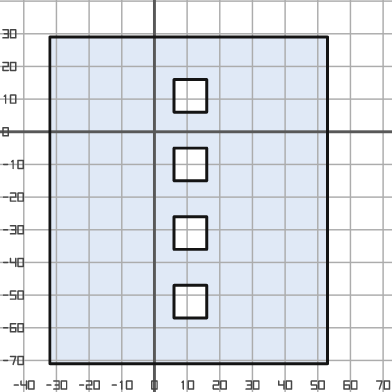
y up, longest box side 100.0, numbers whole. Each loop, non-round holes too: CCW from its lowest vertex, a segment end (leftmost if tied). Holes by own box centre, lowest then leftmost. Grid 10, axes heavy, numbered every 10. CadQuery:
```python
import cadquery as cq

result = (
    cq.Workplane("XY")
    .moveTo(-32.0, -71.0)
    .lineTo(53.0, -71.0)
    .lineTo(53.0, 29.0)
    .lineTo(-32.0, 29.0)
    .close()
    .moveTo(6.0, -57.0)
    .lineTo(16.0, -57.0)
    .lineTo(16.0, -47.0)
    .lineTo(6.0, -47.0)
    .close()
    .moveTo(6.0, -36.0)
    .lineTo(16.0, -36.0)
    .lineTo(16.0, -26.0)
    .lineTo(6.0, -26.0)
    .close()
    .moveTo(6.0, -15.0)
    .lineTo(16.0, -15.0)
    .lineTo(16.0, -5.0)
    .lineTo(6.0, -5.0)
    .close()
    .moveTo(6.0, 6.0)
    .lineTo(16.0, 6.0)
    .lineTo(16.0, 16.0)
    .lineTo(6.0, 16.0)
    .close()
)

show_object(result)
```